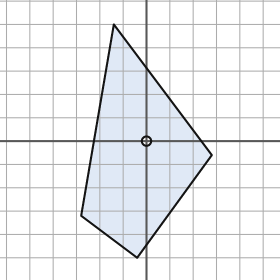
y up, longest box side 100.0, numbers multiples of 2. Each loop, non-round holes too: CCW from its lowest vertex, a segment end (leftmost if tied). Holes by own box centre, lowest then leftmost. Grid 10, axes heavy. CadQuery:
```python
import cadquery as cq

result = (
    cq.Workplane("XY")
    .moveTo(-4.0, -50.0)
    .lineTo(28.0, -6.0)
    .lineTo(-14.0, 50.0)
    .lineTo(-28.0, -32.0)
    .close()
    .moveTo(0.0, 0.0)
    .circle(2.0)
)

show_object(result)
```